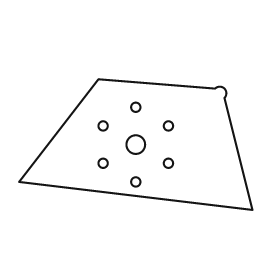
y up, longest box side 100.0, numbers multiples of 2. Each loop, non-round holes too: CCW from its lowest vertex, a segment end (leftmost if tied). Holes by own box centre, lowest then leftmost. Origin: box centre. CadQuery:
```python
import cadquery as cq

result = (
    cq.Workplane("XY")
    .moveTo(50.0, -28.0)
    .lineTo(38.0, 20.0)
    .threePointArc((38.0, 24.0), (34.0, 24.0))
    .lineTo(-16.0, 28.0)
    .lineTo(-50.0, -16.0)
    .close()
    .moveTo(0.0, -16.0)
    .circle(2.0)
    .moveTo(-14.0, -8.0)
    .circle(2.0)
    .moveTo(14.0, -8.0)
    .circle(2.0)
    .moveTo(0.0, 0.0)
    .circle(4.0)
    .moveTo(-14.0, 8.0)
    .circle(2.0)
    .moveTo(14.0, 8.0)
    .circle(2.0)
    .moveTo(0.0, 16.0)
    .circle(2.0)
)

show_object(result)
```